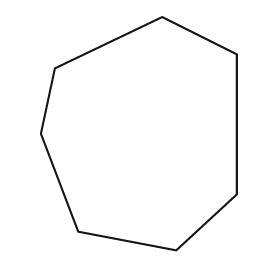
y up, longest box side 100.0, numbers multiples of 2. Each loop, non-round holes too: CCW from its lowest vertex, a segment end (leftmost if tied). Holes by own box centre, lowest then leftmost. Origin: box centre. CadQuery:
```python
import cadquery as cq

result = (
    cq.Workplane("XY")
    .moveTo(16.0, -50.0)
    .lineTo(42.0, -26.0)
    .lineTo(42.0, 34.0)
    .lineTo(10.0, 50.0)
    .lineTo(-36.0, 28.0)
    .lineTo(-42.0, 0.0)
    .lineTo(-26.0, -42.0)
    .close()
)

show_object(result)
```